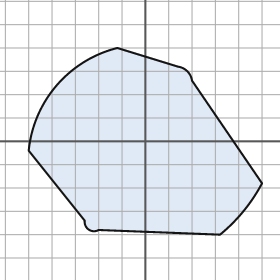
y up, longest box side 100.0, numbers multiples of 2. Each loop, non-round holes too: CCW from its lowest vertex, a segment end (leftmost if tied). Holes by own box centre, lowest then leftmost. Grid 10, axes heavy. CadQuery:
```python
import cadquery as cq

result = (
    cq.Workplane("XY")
    .moveTo(32.0, -40.0)
    .threePointArc((42.0, -30.0), (50.0, -18.0))
    .lineTo(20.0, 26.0)
    .threePointArc((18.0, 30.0), (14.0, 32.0))
    .lineTo(-12.0, 40.0)
    .threePointArc((-38.0, 24.0), (-50.0, -4.0))
    .lineTo(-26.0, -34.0)
    .threePointArc((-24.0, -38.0), (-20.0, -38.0))
    .close()
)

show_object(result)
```